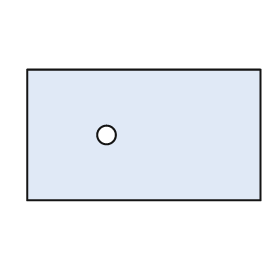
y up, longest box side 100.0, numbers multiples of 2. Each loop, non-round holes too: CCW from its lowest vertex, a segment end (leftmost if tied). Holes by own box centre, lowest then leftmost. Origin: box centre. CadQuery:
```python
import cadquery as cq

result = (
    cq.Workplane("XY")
    .moveTo(-50.0, -28.0)
    .lineTo(50.0, -28.0)
    .lineTo(50.0, 28.0)
    .lineTo(-50.0, 28.0)
    .close()
    .moveTo(-16.0, 0.0)
    .circle(4.0)
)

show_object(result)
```